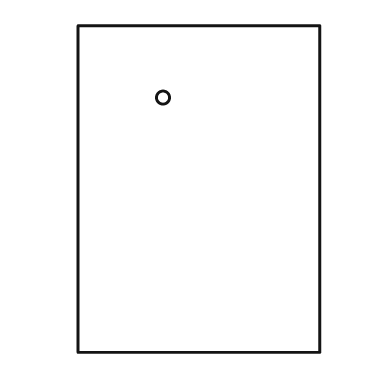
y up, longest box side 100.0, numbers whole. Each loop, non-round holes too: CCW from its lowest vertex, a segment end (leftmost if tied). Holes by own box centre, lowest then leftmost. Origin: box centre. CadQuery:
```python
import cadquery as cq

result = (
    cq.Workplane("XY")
    .moveTo(-37.0, -50.0)
    .lineTo(37.0, -50.0)
    .lineTo(37.0, 50.0)
    .lineTo(-37.0, 50.0)
    .close()
    .moveTo(-11.0, 28.0)
    .circle(2.0)
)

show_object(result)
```